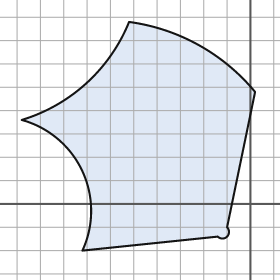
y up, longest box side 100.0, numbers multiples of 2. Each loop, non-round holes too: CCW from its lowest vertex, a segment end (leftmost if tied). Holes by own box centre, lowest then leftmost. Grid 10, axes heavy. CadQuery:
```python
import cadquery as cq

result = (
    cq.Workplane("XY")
    .moveTo(-72.0, -20.0)
    .lineTo(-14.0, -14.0)
    .threePointArc((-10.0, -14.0), (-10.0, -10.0))
    .lineTo(2.0, 48.0)
    .threePointArc((-22.0, 68.0), (-52.0, 78.0))
    .threePointArc((-70.0, 52.0), (-98.0, 36.0))
    .threePointArc((-72.0, 14.0), (-72.0, -20.0))
    .close()
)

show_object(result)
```